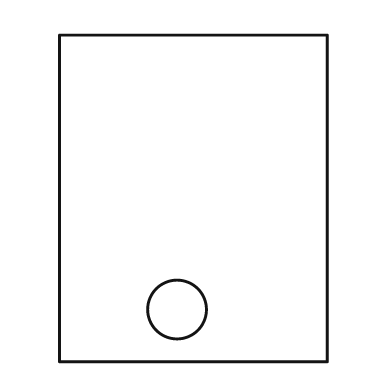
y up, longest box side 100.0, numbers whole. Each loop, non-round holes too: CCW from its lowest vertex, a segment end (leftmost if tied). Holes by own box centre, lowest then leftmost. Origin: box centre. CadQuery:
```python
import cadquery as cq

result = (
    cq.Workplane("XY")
    .moveTo(-41.0, -50.0)
    .lineTo(41.0, -50.0)
    .lineTo(41.0, 50.0)
    .lineTo(-41.0, 50.0)
    .close()
    .moveTo(-5.0, -34.0)
    .circle(9.0)
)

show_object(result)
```